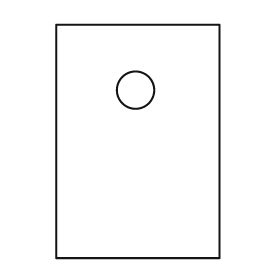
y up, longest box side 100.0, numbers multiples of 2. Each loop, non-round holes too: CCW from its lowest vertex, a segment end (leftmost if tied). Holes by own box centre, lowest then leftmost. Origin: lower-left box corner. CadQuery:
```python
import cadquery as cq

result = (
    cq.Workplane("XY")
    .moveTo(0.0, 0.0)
    .lineTo(70.0, 0.0)
    .lineTo(70.0, 100.0)
    .lineTo(0.0, 100.0)
    .close()
    .moveTo(34.0, 72.0)
    .circle(8.0)
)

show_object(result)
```